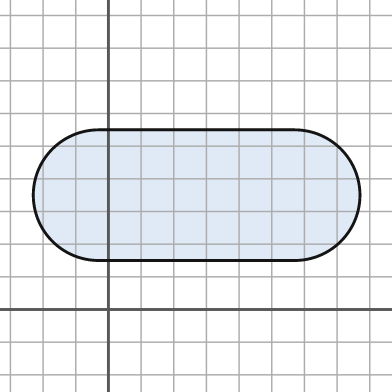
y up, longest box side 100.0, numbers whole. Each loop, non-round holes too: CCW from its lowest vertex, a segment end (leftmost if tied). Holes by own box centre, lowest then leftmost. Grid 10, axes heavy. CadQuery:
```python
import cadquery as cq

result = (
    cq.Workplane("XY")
    .moveTo(-3.0, 15.0)
    .lineTo(57.0, 15.0)
    .threePointArc((77.0, 35.0), (57.0, 55.0))
    .lineTo(-3.0, 55.0)
    .threePointArc((-23.0, 35.0), (-3.0, 15.0))
    .close()
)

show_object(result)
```